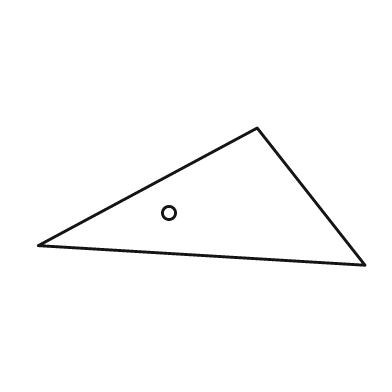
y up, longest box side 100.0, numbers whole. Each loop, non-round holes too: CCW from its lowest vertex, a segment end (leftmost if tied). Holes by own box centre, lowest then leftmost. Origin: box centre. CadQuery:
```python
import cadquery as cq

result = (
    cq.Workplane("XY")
    .moveTo(50.0, -21.0)
    .lineTo(17.0, 21.0)
    .lineTo(-50.0, -15.0)
    .close()
    .moveTo(-10.0, -5.0)
    .circle(2.0)
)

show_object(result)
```